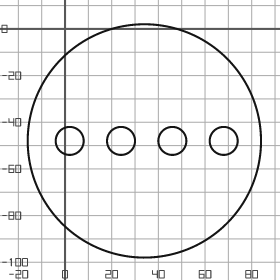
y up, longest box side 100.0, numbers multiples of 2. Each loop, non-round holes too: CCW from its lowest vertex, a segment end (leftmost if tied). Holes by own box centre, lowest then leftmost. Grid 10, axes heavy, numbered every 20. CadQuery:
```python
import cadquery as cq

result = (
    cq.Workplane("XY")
    .moveTo(34.0, -48.0)
    .circle(50.0)
    .moveTo(2.0, -48.0)
    .circle(6.0)
    .moveTo(24.0, -48.0)
    .circle(6.0)
    .moveTo(46.0, -48.0)
    .circle(6.0)
    .moveTo(68.0, -48.0)
    .circle(6.0)
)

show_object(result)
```